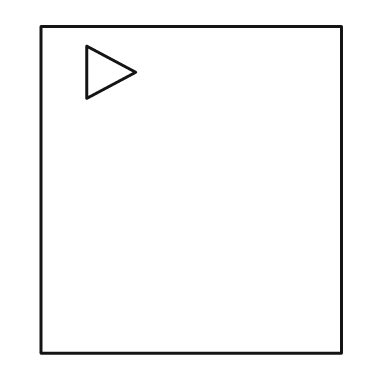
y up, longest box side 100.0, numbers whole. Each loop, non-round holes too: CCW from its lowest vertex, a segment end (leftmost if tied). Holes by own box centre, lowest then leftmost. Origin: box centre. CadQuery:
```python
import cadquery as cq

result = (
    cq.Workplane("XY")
    .moveTo(-46.0, -50.0)
    .lineTo(46.0, -50.0)
    .lineTo(46.0, 50.0)
    .lineTo(-46.0, 50.0)
    .close()
    .moveTo(-32.0, 28.0)
    .lineTo(-17.0, 36.0)
    .lineTo(-32.0, 44.0)
    .close()
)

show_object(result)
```